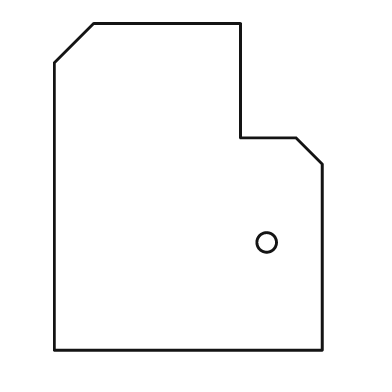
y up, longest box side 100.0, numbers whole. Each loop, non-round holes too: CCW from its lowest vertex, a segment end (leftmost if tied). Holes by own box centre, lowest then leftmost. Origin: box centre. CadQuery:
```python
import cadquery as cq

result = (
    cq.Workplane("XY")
    .moveTo(-41.0, -50.0)
    .lineTo(41.0, -50.0)
    .lineTo(41.0, 7.0)
    .lineTo(33.0, 15.0)
    .lineTo(16.0, 15.0)
    .lineTo(16.0, 50.0)
    .lineTo(-29.0, 50.0)
    .lineTo(-41.0, 38.0)
    .close()
    .moveTo(24.0, -17.0)
    .circle(3.0)
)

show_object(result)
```